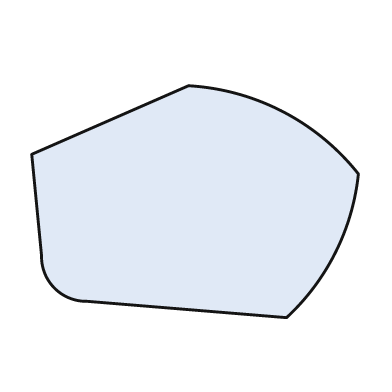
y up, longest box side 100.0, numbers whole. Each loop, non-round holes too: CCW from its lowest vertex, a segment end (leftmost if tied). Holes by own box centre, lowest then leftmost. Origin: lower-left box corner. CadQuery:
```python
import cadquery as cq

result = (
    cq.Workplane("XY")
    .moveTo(78.0, 0.0)
    .threePointArc((93.0, 20.0), (100.0, 44.0))
    .threePointArc((77.0, 63.0), (48.0, 71.0))
    .lineTo(0.0, 50.0)
    .lineTo(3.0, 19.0)
    .threePointArc((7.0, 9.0), (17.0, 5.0))
    .close()
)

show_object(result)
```